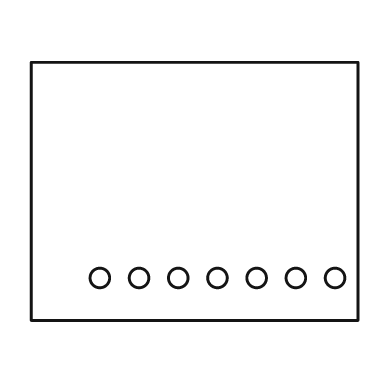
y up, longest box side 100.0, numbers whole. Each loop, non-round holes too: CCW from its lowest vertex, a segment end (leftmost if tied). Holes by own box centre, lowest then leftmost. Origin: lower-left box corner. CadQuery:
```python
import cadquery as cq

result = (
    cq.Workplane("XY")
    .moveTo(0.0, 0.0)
    .lineTo(100.0, 0.0)
    .lineTo(100.0, 79.0)
    .lineTo(0.0, 79.0)
    .close()
    .moveTo(21.0, 13.0)
    .circle(3.0)
    .moveTo(33.0, 13.0)
    .circle(3.0)
    .moveTo(45.0, 13.0)
    .circle(3.0)
    .moveTo(57.0, 13.0)
    .circle(3.0)
    .moveTo(69.0, 13.0)
    .circle(3.0)
    .moveTo(81.0, 13.0)
    .circle(3.0)
    .moveTo(93.0, 13.0)
    .circle(3.0)
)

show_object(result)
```